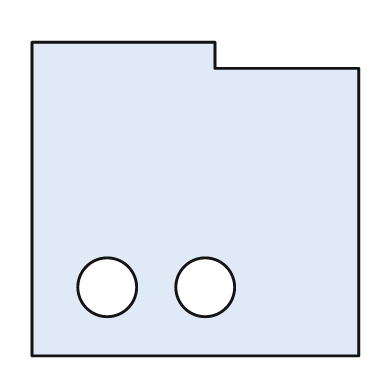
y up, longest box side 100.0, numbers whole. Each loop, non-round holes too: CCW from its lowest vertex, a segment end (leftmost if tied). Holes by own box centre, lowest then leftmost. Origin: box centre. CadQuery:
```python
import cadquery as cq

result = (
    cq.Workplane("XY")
    .moveTo(-50.0, -48.0)
    .lineTo(50.0, -48.0)
    .lineTo(50.0, 40.0)
    .lineTo(6.0, 40.0)
    .lineTo(6.0, 48.0)
    .lineTo(-50.0, 48.0)
    .close()
    .moveTo(-27.0, -27.0)
    .circle(9.0)
    .moveTo(3.0, -27.0)
    .circle(9.0)
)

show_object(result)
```